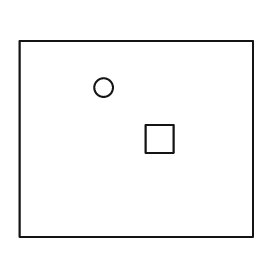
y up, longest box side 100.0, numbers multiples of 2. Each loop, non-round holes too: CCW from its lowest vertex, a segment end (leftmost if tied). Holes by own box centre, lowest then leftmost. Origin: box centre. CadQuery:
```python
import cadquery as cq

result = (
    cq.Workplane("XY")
    .moveTo(-50.0, -42.0)
    .lineTo(50.0, -42.0)
    .lineTo(50.0, 42.0)
    .lineTo(-50.0, 42.0)
    .close()
    .moveTo(4.0, -6.0)
    .lineTo(16.0, -6.0)
    .lineTo(16.0, 6.0)
    .lineTo(4.0, 6.0)
    .close()
    .moveTo(-14.0, 22.0)
    .circle(4.0)
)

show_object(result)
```